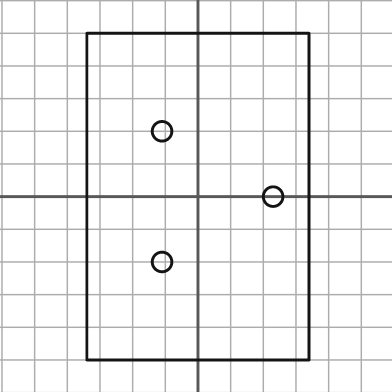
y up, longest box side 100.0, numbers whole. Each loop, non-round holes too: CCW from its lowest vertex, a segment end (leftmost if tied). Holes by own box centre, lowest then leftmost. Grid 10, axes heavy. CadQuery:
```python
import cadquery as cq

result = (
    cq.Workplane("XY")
    .moveTo(-34.0, -50.0)
    .lineTo(34.0, -50.0)
    .lineTo(34.0, 50.0)
    .lineTo(-34.0, 50.0)
    .close()
    .moveTo(-11.0, -20.0)
    .circle(3.0)
    .moveTo(23.0, 0.0)
    .circle(3.0)
    .moveTo(-11.0, 20.0)
    .circle(3.0)
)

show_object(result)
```